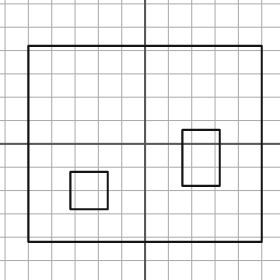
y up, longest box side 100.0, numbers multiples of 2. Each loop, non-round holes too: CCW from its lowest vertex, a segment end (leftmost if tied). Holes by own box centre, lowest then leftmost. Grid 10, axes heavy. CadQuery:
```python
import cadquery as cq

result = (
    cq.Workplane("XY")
    .moveTo(-50.0, -42.0)
    .lineTo(50.0, -42.0)
    .lineTo(50.0, 42.0)
    .lineTo(-50.0, 42.0)
    .close()
    .moveTo(-32.0, -28.0)
    .lineTo(-16.0, -28.0)
    .lineTo(-16.0, -12.0)
    .lineTo(-32.0, -12.0)
    .close()
    .moveTo(16.0, -18.0)
    .lineTo(32.0, -18.0)
    .lineTo(32.0, 6.0)
    .lineTo(16.0, 6.0)
    .close()
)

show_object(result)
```